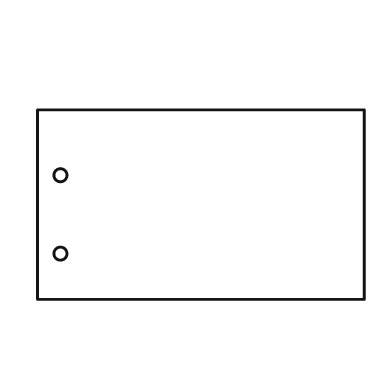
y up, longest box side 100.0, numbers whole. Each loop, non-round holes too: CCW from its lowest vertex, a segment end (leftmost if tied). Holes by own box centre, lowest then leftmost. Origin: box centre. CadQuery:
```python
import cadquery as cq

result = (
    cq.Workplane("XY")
    .moveTo(-50.0, -29.0)
    .lineTo(50.0, -29.0)
    .lineTo(50.0, 29.0)
    .lineTo(-50.0, 29.0)
    .close()
    .moveTo(-43.0, -15.0)
    .circle(2.0)
    .moveTo(-43.0, 9.0)
    .circle(2.0)
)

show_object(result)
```